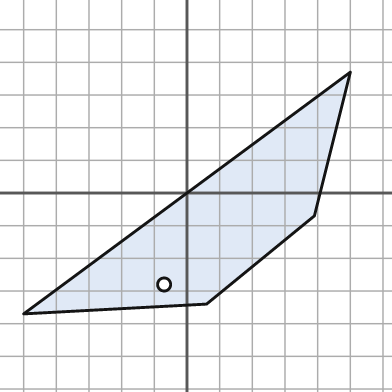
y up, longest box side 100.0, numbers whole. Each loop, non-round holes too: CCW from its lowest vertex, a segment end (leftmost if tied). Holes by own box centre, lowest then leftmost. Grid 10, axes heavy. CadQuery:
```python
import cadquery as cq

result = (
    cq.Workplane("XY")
    .moveTo(-50.0, -37.0)
    .lineTo(6.0, -34.0)
    .lineTo(39.0, -7.0)
    .lineTo(50.0, 37.0)
    .close()
    .moveTo(-7.0, -28.0)
    .circle(2.0)
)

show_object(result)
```